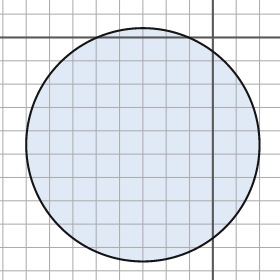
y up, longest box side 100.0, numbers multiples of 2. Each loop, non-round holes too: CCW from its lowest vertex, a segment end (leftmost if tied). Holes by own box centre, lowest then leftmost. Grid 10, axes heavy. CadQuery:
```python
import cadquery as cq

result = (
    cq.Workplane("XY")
    .moveTo(-30.0, -46.0)
    .circle(50.0)
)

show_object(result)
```